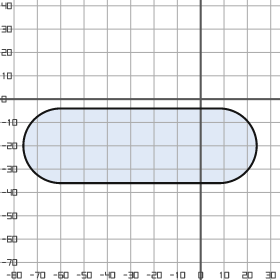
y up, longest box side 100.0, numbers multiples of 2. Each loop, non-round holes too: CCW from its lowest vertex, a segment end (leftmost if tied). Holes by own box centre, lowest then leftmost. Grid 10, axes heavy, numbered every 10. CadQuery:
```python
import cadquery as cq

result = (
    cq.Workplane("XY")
    .moveTo(-60.0, -36.0)
    .lineTo(8.0, -36.0)
    .threePointArc((24.0, -20.0), (8.0, -4.0))
    .lineTo(-60.0, -4.0)
    .threePointArc((-76.0, -20.0), (-60.0, -36.0))
    .close()
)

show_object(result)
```